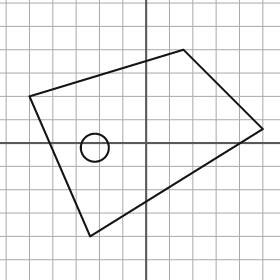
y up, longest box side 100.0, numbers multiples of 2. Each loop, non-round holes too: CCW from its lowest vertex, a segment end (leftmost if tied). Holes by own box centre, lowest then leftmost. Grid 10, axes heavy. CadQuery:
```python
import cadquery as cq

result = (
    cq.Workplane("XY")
    .moveTo(-24.0, -40.0)
    .lineTo(50.0, 6.0)
    .lineTo(16.0, 40.0)
    .lineTo(-50.0, 20.0)
    .close()
    .moveTo(-22.0, -2.0)
    .circle(6.0)
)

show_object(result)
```